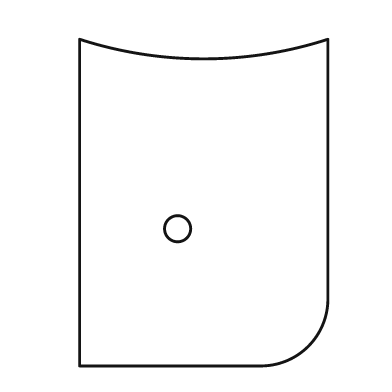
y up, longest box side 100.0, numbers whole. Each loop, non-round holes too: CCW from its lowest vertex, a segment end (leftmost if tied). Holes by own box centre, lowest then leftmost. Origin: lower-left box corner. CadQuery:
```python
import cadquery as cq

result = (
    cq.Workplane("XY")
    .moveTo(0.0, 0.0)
    .lineTo(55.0, 0.0)
    .threePointArc((70.0, 6.0), (76.0, 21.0))
    .lineTo(76.0, 100.0)
    .threePointArc((38.0, 94.0), (0.0, 100.0))
    .close()
    .moveTo(30.0, 42.0)
    .circle(4.0)
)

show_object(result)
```